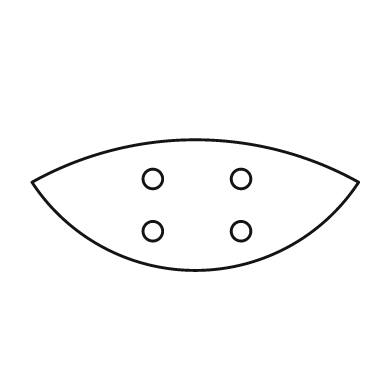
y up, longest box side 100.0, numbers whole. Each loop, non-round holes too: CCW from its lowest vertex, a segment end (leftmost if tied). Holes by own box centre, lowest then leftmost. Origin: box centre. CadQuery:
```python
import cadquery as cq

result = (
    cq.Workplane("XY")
    .moveTo(-50.0, 7.0)
    .threePointArc((0.0, -20.0), (50.0, 7.0))
    .threePointArc((0.0, 20.0), (-50.0, 7.0))
    .close()
    .moveTo(-13.0, -8.0)
    .circle(3.0)
    .moveTo(14.0, -8.0)
    .circle(3.0)
    .moveTo(-13.0, 8.0)
    .circle(3.0)
    .moveTo(14.0, 8.0)
    .circle(3.0)
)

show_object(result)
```